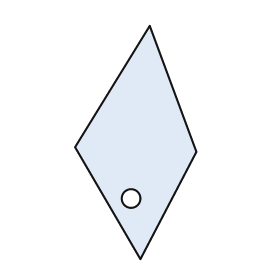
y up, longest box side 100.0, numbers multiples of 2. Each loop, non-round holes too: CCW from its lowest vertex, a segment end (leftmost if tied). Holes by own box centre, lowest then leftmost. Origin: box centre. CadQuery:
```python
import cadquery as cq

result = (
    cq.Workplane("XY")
    .moveTo(2.0, -50.0)
    .lineTo(26.0, -4.0)
    .lineTo(6.0, 50.0)
    .lineTo(-26.0, -2.0)
    .close()
    .moveTo(-2.0, -24.0)
    .circle(4.0)
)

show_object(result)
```